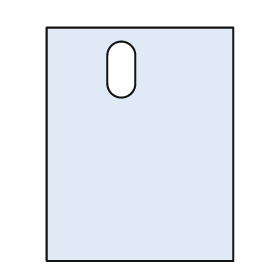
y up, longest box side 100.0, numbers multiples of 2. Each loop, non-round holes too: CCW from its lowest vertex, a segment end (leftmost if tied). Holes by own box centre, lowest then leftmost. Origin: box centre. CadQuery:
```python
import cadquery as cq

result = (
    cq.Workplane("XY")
    .moveTo(-40.0, -50.0)
    .lineTo(40.0, -50.0)
    .lineTo(40.0, 50.0)
    .lineTo(-40.0, 50.0)
    .close()
    .moveTo(-14.0, 26.0)
    .threePointArc((-8.0, 20.0), (-2.0, 26.0))
    .lineTo(-2.0, 38.0)
    .threePointArc((-8.0, 44.0), (-14.0, 38.0))
    .close()
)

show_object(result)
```